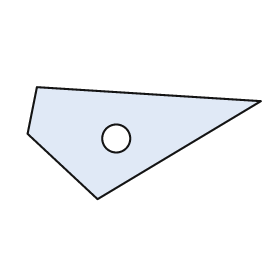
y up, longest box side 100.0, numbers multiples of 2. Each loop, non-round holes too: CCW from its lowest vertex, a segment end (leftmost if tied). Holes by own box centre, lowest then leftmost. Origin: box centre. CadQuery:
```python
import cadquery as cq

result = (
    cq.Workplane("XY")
    .moveTo(-20.0, -24.0)
    .lineTo(50.0, 18.0)
    .lineTo(-46.0, 24.0)
    .lineTo(-50.0, 4.0)
    .close()
    .moveTo(-12.0, 2.0)
    .circle(6.0)
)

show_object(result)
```